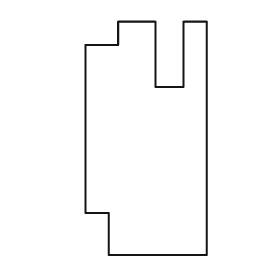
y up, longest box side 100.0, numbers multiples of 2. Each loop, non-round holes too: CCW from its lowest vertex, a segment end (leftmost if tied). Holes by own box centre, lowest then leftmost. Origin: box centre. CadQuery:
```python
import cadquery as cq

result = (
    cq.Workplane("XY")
    .moveTo(-16.0, -50.0)
    .lineTo(26.0, -50.0)
    .lineTo(26.0, 50.0)
    .lineTo(16.0, 50.0)
    .lineTo(16.0, 22.0)
    .lineTo(4.0, 22.0)
    .lineTo(4.0, 50.0)
    .lineTo(-12.0, 50.0)
    .lineTo(-12.0, 40.0)
    .lineTo(-26.0, 40.0)
    .lineTo(-26.0, -32.0)
    .lineTo(-16.0, -32.0)
    .close()
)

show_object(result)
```